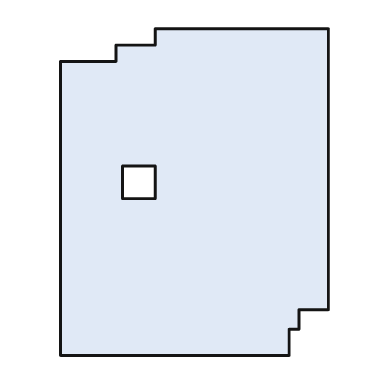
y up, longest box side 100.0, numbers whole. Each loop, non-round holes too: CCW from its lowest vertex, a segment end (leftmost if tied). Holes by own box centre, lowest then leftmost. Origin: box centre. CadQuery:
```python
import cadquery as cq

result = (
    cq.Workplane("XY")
    .moveTo(-41.0, -50.0)
    .lineTo(29.0, -50.0)
    .lineTo(29.0, -42.0)
    .lineTo(32.0, -42.0)
    .lineTo(32.0, -36.0)
    .lineTo(41.0, -36.0)
    .lineTo(41.0, 50.0)
    .lineTo(-12.0, 50.0)
    .lineTo(-12.0, 45.0)
    .lineTo(-24.0, 45.0)
    .lineTo(-24.0, 40.0)
    .lineTo(-41.0, 40.0)
    .close()
    .moveTo(-22.0, -2.0)
    .lineTo(-12.0, -2.0)
    .lineTo(-12.0, 8.0)
    .lineTo(-22.0, 8.0)
    .close()
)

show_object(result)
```